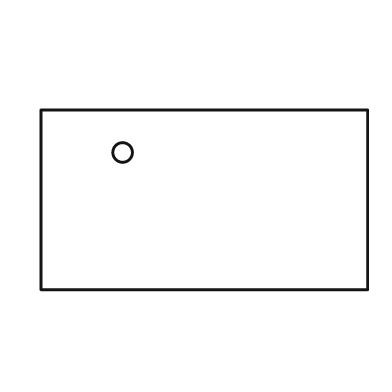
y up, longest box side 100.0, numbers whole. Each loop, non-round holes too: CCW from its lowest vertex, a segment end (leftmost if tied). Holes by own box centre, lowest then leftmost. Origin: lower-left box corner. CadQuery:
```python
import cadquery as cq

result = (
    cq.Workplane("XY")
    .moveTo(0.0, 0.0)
    .lineTo(100.0, 0.0)
    .lineTo(100.0, 55.0)
    .lineTo(0.0, 55.0)
    .close()
    .moveTo(25.0, 42.0)
    .circle(3.0)
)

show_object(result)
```